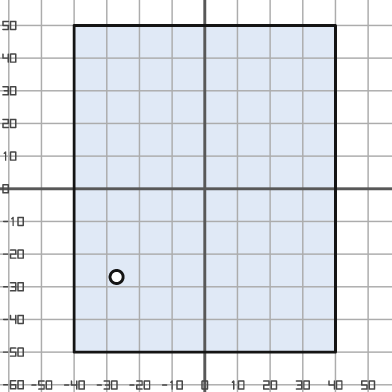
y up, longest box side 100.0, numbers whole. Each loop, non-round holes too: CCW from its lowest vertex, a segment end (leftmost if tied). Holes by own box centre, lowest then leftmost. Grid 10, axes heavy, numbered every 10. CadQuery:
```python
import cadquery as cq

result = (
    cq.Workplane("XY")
    .moveTo(-40.0, -50.0)
    .lineTo(40.0, -50.0)
    .lineTo(40.0, 50.0)
    .lineTo(-40.0, 50.0)
    .close()
    .moveTo(-27.0, -27.0)
    .circle(2.0)
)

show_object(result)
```